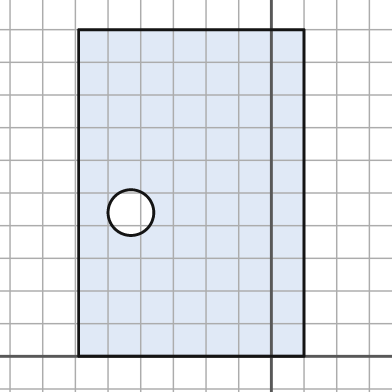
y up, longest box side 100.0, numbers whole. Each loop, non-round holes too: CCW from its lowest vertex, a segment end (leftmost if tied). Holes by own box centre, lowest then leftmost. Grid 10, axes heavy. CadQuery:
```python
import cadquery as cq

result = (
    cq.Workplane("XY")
    .moveTo(-59.0, 0.0)
    .lineTo(10.0, 0.0)
    .lineTo(10.0, 100.0)
    .lineTo(-59.0, 100.0)
    .close()
    .moveTo(-43.0, 44.0)
    .circle(7.0)
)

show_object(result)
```